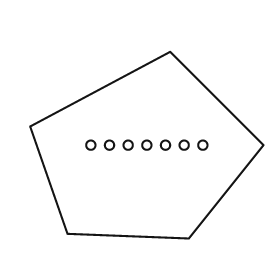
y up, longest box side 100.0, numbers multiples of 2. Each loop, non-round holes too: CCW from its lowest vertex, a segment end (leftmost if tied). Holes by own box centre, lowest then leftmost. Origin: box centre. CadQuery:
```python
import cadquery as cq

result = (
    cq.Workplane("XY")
    .moveTo(18.0, -40.0)
    .lineTo(50.0, 0.0)
    .lineTo(10.0, 40.0)
    .lineTo(-50.0, 8.0)
    .lineTo(-34.0, -38.0)
    .close()
    .moveTo(-24.0, 0.0)
    .circle(2.0)
    .moveTo(-16.0, 0.0)
    .circle(2.0)
    .moveTo(-8.0, 0.0)
    .circle(2.0)
    .moveTo(0.0, 0.0)
    .circle(2.0)
    .moveTo(8.0, 0.0)
    .circle(2.0)
    .moveTo(16.0, 0.0)
    .circle(2.0)
    .moveTo(24.0, 0.0)
    .circle(2.0)
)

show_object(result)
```